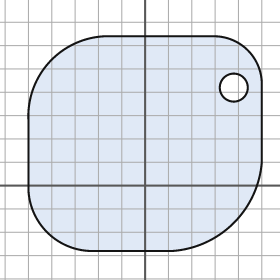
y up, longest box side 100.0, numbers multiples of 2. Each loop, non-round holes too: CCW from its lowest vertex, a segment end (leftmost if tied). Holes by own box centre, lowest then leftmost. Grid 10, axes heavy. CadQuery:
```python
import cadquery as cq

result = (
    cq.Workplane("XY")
    .moveTo(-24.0, -28.0)
    .lineTo(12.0, -28.0)
    .threePointArc((38.0, -16.0), (50.0, 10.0))
    .lineTo(50.0, 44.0)
    .threePointArc((44.0, 58.0), (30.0, 64.0))
    .lineTo(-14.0, 64.0)
    .threePointArc((-40.0, 54.0), (-50.0, 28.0))
    .lineTo(-50.0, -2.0)
    .threePointArc((-42.0, -20.0), (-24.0, -28.0))
    .close()
    .moveTo(38.0, 42.0)
    .circle(6.0)
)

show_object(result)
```